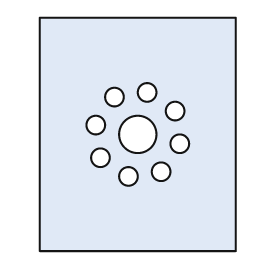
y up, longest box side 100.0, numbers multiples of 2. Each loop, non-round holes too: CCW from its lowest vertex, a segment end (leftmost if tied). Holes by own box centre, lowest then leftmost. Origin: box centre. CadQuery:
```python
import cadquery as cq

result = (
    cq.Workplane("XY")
    .moveTo(-42.0, -50.0)
    .lineTo(42.0, -50.0)
    .lineTo(42.0, 50.0)
    .lineTo(-42.0, 50.0)
    .close()
    .moveTo(-4.0, -18.0)
    .circle(4.0)
    .moveTo(10.0, -16.0)
    .circle(4.0)
    .moveTo(-16.0, -10.0)
    .circle(4.0)
    .moveTo(18.0, -4.0)
    .circle(4.0)
    .moveTo(0.0, 0.0)
    .circle(8.0)
    .moveTo(-18.0, 4.0)
    .circle(4.0)
    .moveTo(16.0, 10.0)
    .circle(4.0)
    .moveTo(-10.0, 16.0)
    .circle(4.0)
    .moveTo(4.0, 18.0)
    .circle(4.0)
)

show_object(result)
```